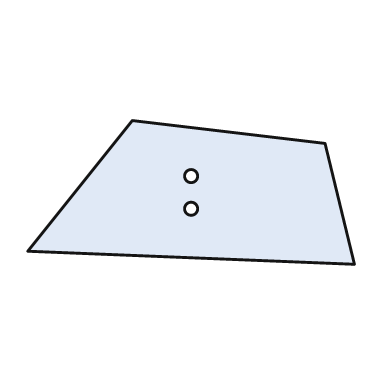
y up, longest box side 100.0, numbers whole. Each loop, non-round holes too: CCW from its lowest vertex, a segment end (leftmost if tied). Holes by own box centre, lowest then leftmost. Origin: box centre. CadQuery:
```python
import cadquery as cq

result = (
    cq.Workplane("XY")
    .moveTo(50.0, -22.0)
    .lineTo(41.0, 15.0)
    .lineTo(-18.0, 22.0)
    .lineTo(-50.0, -18.0)
    .close()
    .moveTo(0.0, -5.0)
    .circle(2.0)
    .moveTo(0.0, 5.0)
    .circle(2.0)
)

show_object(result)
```